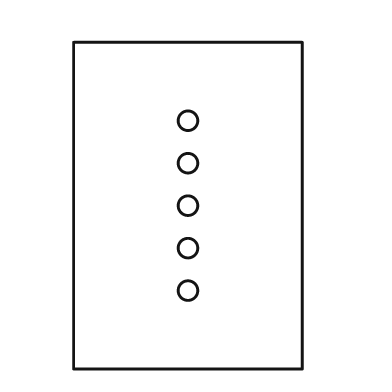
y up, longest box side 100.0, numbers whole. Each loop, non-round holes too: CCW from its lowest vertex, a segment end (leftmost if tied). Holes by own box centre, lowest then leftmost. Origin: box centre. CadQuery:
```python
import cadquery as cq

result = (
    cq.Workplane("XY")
    .moveTo(-35.0, -50.0)
    .lineTo(35.0, -50.0)
    .lineTo(35.0, 50.0)
    .lineTo(-35.0, 50.0)
    .close()
    .moveTo(0.0, -26.0)
    .circle(3.0)
    .moveTo(0.0, -13.0)
    .circle(3.0)
    .moveTo(0.0, 0.0)
    .circle(3.0)
    .moveTo(0.0, 13.0)
    .circle(3.0)
    .moveTo(0.0, 26.0)
    .circle(3.0)
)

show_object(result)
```